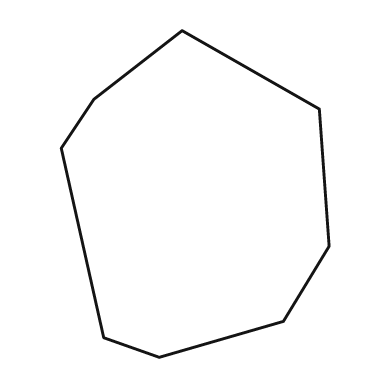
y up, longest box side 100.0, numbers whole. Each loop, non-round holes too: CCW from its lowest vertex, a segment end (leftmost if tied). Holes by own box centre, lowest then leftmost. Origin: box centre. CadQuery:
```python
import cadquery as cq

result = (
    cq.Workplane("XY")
    .moveTo(-11.0, -50.0)
    .lineTo(27.0, -39.0)
    .lineTo(41.0, -16.0)
    .lineTo(38.0, 26.0)
    .lineTo(-4.0, 50.0)
    .lineTo(-31.0, 29.0)
    .lineTo(-41.0, 14.0)
    .lineTo(-28.0, -44.0)
    .close()
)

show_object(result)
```